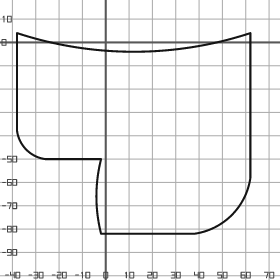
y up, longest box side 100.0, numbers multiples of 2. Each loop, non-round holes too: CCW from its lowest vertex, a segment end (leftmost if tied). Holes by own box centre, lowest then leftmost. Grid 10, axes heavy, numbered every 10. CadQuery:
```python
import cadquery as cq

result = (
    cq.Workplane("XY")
    .moveTo(-2.0, -82.0)
    .lineTo(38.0, -82.0)
    .threePointArc((54.0, -74.0), (62.0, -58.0))
    .lineTo(62.0, 4.0)
    .threePointArc((12.0, -4.0), (-38.0, 4.0))
    .lineTo(-38.0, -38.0)
    .threePointArc((-34.0, -46.0), (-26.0, -50.0))
    .lineTo(-2.0, -50.0)
    .threePointArc((-4.0, -66.0), (-2.0, -82.0))
    .close()
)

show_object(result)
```